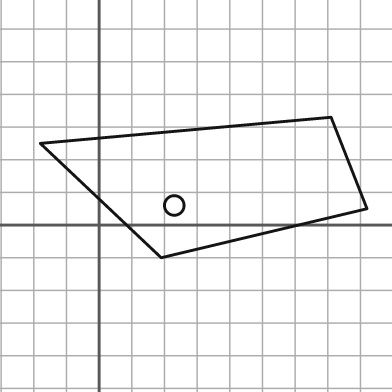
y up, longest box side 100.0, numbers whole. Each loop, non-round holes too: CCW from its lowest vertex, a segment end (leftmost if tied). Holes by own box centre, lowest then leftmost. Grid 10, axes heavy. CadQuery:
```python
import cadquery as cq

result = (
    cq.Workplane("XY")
    .moveTo(19.0, -10.0)
    .lineTo(82.0, 5.0)
    .lineTo(71.0, 33.0)
    .lineTo(-18.0, 25.0)
    .close()
    .moveTo(23.0, 6.0)
    .circle(3.0)
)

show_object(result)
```